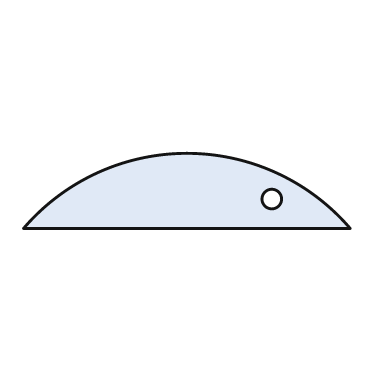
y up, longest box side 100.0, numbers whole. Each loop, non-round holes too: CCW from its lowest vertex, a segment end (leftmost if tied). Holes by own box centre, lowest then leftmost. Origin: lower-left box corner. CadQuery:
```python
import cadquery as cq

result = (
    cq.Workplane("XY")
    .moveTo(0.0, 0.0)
    .lineTo(100.0, 0.0)
    .threePointArc((50.0, 23.0), (0.0, 0.0))
    .close()
    .moveTo(76.0, 9.0)
    .circle(3.0)
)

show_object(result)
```